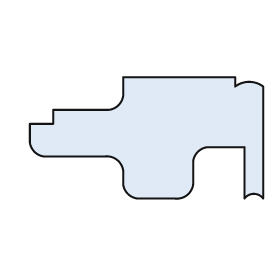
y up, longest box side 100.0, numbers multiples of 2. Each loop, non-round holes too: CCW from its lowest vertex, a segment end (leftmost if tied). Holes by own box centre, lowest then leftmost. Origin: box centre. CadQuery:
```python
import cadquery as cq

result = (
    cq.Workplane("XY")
    .moveTo(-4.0, -26.0)
    .lineTo(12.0, -26.0)
    .threePointArc((18.0, -24.0), (20.0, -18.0))
    .lineTo(20.0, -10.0)
    .threePointArc((22.0, -6.0), (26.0, -4.0))
    .lineTo(42.0, -4.0)
    .lineTo(42.0, -26.0)
    .threePointArc((46.0, -24.0), (50.0, -26.0))
    .lineTo(50.0, 22.0)
    .threePointArc((44.0, 24.0), (38.0, 22.0))
    .lineTo(38.0, 26.0)
    .lineTo(-10.0, 26.0)
    .lineTo(-10.0, 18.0)
    .threePointArc((-12.0, 14.0), (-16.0, 12.0))
    .lineTo(-40.0, 12.0)
    .lineTo(-40.0, 6.0)
    .lineTo(-50.0, 6.0)
    .lineTo(-50.0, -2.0)
    .threePointArc((-48.0, -6.0), (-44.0, -8.0))
    .lineTo(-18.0, -8.0)
    .threePointArc((-12.0, -10.0), (-10.0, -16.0))
    .lineTo(-10.0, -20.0)
    .threePointArc((-8.0, -24.0), (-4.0, -26.0))
    .close()
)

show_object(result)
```